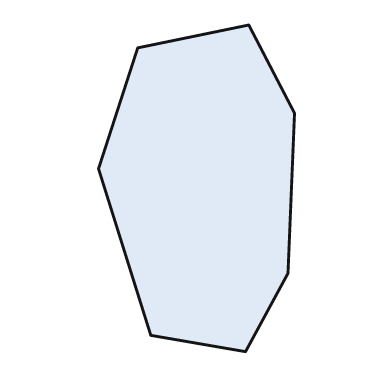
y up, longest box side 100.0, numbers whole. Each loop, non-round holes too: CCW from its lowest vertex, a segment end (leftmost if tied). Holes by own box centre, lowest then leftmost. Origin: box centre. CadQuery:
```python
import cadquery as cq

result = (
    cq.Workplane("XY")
    .moveTo(15.0, -50.0)
    .lineTo(28.0, -26.0)
    .lineTo(30.0, 23.0)
    .lineTo(16.0, 50.0)
    .lineTo(-18.0, 43.0)
    .lineTo(-30.0, 6.0)
    .lineTo(-14.0, -45.0)
    .close()
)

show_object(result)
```